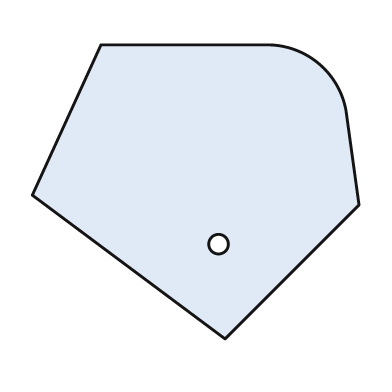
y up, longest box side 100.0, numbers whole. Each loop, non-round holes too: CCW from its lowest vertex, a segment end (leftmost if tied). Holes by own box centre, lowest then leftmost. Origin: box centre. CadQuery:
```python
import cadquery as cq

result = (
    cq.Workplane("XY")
    .moveTo(9.0, -45.0)
    .lineTo(50.0, -4.0)
    .lineTo(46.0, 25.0)
    .threePointArc((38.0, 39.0), (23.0, 45.0))
    .lineTo(-29.0, 45.0)
    .lineTo(-50.0, -1.0)
    .close()
    .moveTo(7.0, -16.0)
    .circle(3.0)
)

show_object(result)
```